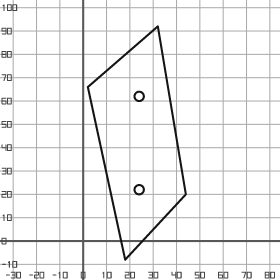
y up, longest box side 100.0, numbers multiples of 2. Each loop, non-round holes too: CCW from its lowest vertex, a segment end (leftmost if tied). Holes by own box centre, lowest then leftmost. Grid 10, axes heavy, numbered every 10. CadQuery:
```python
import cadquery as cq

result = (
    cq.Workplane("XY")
    .moveTo(18.0, -8.0)
    .lineTo(44.0, 20.0)
    .lineTo(32.0, 92.0)
    .lineTo(2.0, 66.0)
    .close()
    .moveTo(24.0, 22.0)
    .circle(2.0)
    .moveTo(24.0, 62.0)
    .circle(2.0)
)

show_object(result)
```